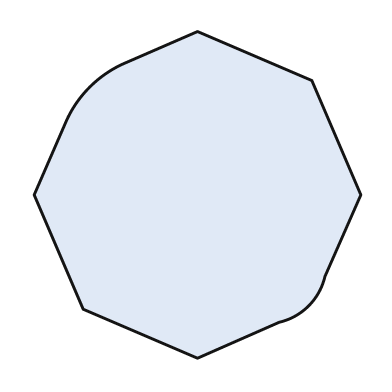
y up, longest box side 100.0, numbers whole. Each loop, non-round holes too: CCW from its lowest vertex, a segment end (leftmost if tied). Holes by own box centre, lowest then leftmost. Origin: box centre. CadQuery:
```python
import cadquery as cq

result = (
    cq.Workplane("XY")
    .moveTo(0.0, -50.0)
    .lineTo(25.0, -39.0)
    .threePointArc((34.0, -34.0), (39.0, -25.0))
    .lineTo(50.0, 0.0)
    .lineTo(35.0, 35.0)
    .lineTo(0.0, 50.0)
    .lineTo(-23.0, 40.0)
    .threePointArc((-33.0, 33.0), (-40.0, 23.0))
    .lineTo(-50.0, 0.0)
    .lineTo(-35.0, -35.0)
    .close()
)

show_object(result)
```